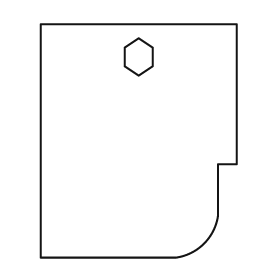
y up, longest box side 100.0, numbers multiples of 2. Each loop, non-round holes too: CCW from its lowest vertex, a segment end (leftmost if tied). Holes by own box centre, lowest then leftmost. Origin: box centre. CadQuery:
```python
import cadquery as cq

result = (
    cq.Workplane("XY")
    .moveTo(-42.0, -50.0)
    .lineTo(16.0, -50.0)
    .threePointArc((28.0, -44.0), (34.0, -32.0))
    .lineTo(34.0, -10.0)
    .lineTo(42.0, -10.0)
    .lineTo(42.0, 50.0)
    .lineTo(-42.0, 50.0)
    .close()
    .moveTo(0.0, 28.0)
    .lineTo(6.0, 32.0)
    .lineTo(6.0, 40.0)
    .lineTo(0.0, 44.0)
    .lineTo(-6.0, 40.0)
    .lineTo(-6.0, 32.0)
    .close()
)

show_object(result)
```